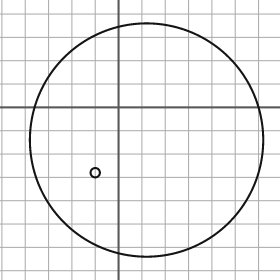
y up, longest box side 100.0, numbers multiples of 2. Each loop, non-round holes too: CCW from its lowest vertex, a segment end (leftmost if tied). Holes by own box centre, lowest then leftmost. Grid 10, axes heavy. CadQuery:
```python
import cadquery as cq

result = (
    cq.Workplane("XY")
    .moveTo(12.0, -14.0)
    .circle(50.0)
    .moveTo(-10.0, -28.0)
    .circle(2.0)
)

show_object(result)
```